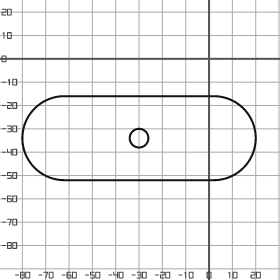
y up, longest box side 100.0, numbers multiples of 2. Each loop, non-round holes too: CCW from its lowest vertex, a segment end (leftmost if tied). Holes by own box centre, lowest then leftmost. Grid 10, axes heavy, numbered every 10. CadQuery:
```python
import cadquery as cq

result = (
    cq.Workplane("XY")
    .moveTo(-62.0, -52.0)
    .lineTo(2.0, -52.0)
    .threePointArc((20.0, -34.0), (2.0, -16.0))
    .lineTo(-62.0, -16.0)
    .threePointArc((-80.0, -34.0), (-62.0, -52.0))
    .close()
    .moveTo(-30.0, -34.0)
    .circle(4.0)
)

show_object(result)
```